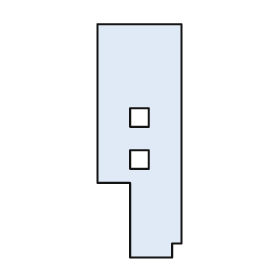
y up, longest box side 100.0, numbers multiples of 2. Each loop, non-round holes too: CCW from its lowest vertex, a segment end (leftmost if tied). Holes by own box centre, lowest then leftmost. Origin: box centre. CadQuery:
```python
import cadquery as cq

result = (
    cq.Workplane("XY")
    .moveTo(-4.0, -50.0)
    .lineTo(14.0, -50.0)
    .lineTo(14.0, -44.0)
    .lineTo(18.0, -44.0)
    .lineTo(18.0, 50.0)
    .lineTo(-18.0, 50.0)
    .lineTo(-18.0, -18.0)
    .lineTo(-4.0, -18.0)
    .close()
    .moveTo(-4.0, -12.0)
    .lineTo(4.0, -12.0)
    .lineTo(4.0, -4.0)
    .lineTo(-4.0, -4.0)
    .close()
    .moveTo(-4.0, 6.0)
    .lineTo(4.0, 6.0)
    .lineTo(4.0, 14.0)
    .lineTo(-4.0, 14.0)
    .close()
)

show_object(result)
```